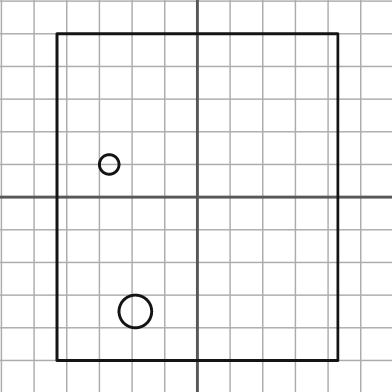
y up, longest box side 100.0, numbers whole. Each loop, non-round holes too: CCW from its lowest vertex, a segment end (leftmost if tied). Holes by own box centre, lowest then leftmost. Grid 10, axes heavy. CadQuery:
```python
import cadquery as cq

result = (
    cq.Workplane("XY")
    .moveTo(-43.0, -50.0)
    .lineTo(43.0, -50.0)
    .lineTo(43.0, 50.0)
    .lineTo(-43.0, 50.0)
    .close()
    .moveTo(-19.0, -35.0)
    .circle(5.0)
    .moveTo(-27.0, 10.0)
    .circle(3.0)
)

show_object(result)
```